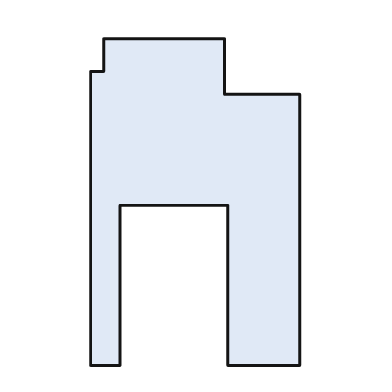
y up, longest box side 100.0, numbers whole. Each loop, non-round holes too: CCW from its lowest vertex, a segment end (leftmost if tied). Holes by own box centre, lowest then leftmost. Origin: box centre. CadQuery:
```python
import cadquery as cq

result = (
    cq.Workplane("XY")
    .moveTo(-32.0, -50.0)
    .lineTo(-23.0, -50.0)
    .lineTo(-23.0, -1.0)
    .lineTo(10.0, -1.0)
    .lineTo(10.0, -50.0)
    .lineTo(32.0, -50.0)
    .lineTo(32.0, 33.0)
    .lineTo(9.0, 33.0)
    .lineTo(9.0, 50.0)
    .lineTo(-28.0, 50.0)
    .lineTo(-28.0, 40.0)
    .lineTo(-32.0, 40.0)
    .close()
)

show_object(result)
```